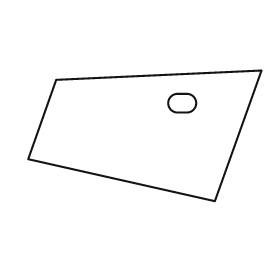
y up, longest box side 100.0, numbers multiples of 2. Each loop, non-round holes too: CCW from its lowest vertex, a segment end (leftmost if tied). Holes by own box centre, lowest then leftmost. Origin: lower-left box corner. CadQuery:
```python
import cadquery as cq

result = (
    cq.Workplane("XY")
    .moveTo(80.0, 0.0)
    .lineTo(100.0, 56.0)
    .lineTo(12.0, 52.0)
    .lineTo(0.0, 18.0)
    .close()
    .moveTo(64.0, 38.0)
    .lineTo(68.0, 38.0)
    .threePointArc((72.0, 42.0), (68.0, 46.0))
    .lineTo(64.0, 46.0)
    .threePointArc((60.0, 42.0), (64.0, 38.0))
    .close()
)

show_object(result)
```